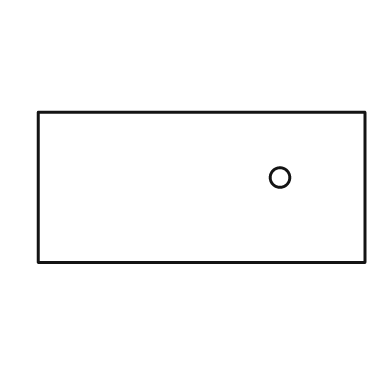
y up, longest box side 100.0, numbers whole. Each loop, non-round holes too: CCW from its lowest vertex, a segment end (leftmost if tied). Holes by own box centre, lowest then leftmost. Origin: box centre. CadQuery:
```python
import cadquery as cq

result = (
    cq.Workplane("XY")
    .moveTo(-50.0, -23.0)
    .lineTo(50.0, -23.0)
    .lineTo(50.0, 23.0)
    .lineTo(-50.0, 23.0)
    .close()
    .moveTo(24.0, 3.0)
    .circle(3.0)
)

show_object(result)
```